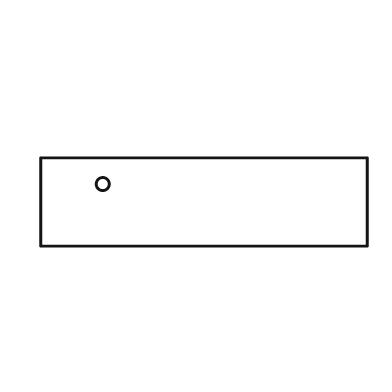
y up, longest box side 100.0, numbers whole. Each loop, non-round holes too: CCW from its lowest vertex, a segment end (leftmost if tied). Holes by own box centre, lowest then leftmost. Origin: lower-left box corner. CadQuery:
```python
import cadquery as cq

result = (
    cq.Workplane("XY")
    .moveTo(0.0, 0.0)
    .lineTo(100.0, 0.0)
    .lineTo(100.0, 27.0)
    .lineTo(0.0, 27.0)
    .close()
    .moveTo(19.0, 19.0)
    .circle(2.0)
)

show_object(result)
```